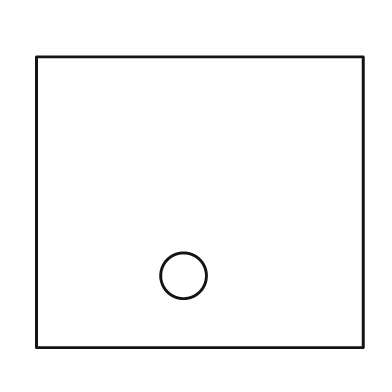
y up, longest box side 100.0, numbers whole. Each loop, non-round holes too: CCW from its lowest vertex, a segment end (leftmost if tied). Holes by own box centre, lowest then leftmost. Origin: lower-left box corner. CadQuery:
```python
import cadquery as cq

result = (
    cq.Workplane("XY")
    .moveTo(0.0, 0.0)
    .lineTo(100.0, 0.0)
    .lineTo(100.0, 89.0)
    .lineTo(0.0, 89.0)
    .close()
    .moveTo(45.0, 22.0)
    .circle(7.0)
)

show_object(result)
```